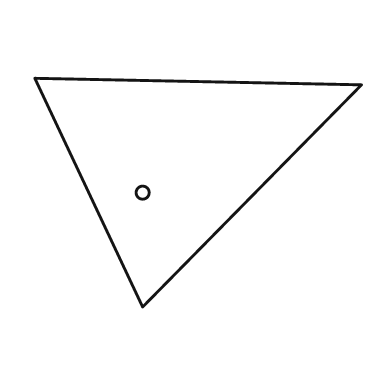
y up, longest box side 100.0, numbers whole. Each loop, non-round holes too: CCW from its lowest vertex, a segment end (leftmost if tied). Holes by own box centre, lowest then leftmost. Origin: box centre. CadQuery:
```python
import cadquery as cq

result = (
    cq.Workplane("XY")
    .moveTo(-17.0, -35.0)
    .lineTo(50.0, 33.0)
    .lineTo(-50.0, 35.0)
    .close()
    .moveTo(-17.0, 0.0)
    .circle(2.0)
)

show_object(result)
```